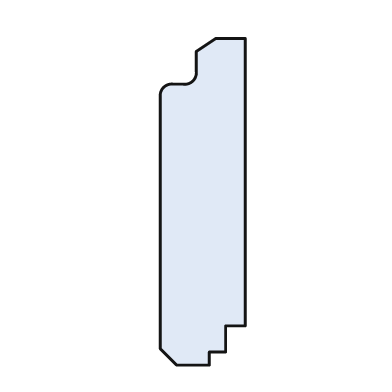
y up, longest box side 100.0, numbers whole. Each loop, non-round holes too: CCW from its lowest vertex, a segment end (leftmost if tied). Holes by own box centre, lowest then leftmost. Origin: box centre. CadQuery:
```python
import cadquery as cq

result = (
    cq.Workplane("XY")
    .moveTo(-8.0, -50.0)
    .lineTo(2.0, -50.0)
    .lineTo(2.0, -46.0)
    .lineTo(7.0, -46.0)
    .lineTo(7.0, -38.0)
    .lineTo(13.0, -38.0)
    .lineTo(13.0, 50.0)
    .lineTo(4.0, 50.0)
    .lineTo(-2.0, 46.0)
    .lineTo(-2.0, 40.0)
    .threePointArc((-3.0, 37.0), (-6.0, 36.0))
    .lineTo(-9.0, 36.0)
    .threePointArc((-12.0, 35.0), (-13.0, 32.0))
    .lineTo(-13.0, -45.0)
    .close()
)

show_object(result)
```